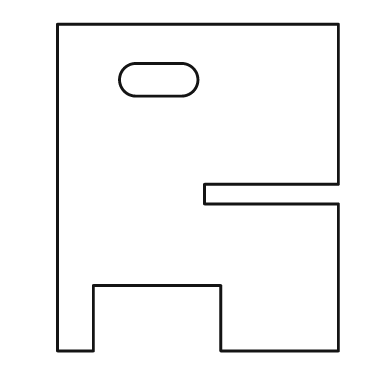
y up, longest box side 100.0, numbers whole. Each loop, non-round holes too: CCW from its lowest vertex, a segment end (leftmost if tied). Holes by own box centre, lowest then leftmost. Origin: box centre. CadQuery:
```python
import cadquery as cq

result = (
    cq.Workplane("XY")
    .moveTo(-43.0, -50.0)
    .lineTo(-32.0, -50.0)
    .lineTo(-32.0, -30.0)
    .lineTo(7.0, -30.0)
    .lineTo(7.0, -50.0)
    .lineTo(43.0, -50.0)
    .lineTo(43.0, -5.0)
    .lineTo(2.0, -5.0)
    .lineTo(2.0, 1.0)
    .lineTo(43.0, 1.0)
    .lineTo(43.0, 50.0)
    .lineTo(-43.0, 50.0)
    .close()
    .moveTo(-19.0, 28.0)
    .lineTo(-5.0, 28.0)
    .threePointArc((0.0, 33.0), (-5.0, 38.0))
    .lineTo(-19.0, 38.0)
    .threePointArc((-24.0, 33.0), (-19.0, 28.0))
    .close()
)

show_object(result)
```